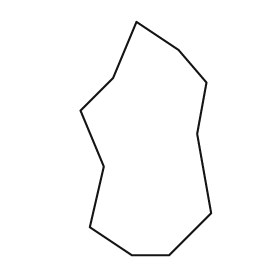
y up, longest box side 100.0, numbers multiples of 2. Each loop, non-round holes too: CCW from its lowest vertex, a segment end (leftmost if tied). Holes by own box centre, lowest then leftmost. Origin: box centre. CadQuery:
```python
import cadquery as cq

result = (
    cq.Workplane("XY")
    .moveTo(-6.0, -50.0)
    .lineTo(10.0, -50.0)
    .lineTo(28.0, -32.0)
    .lineTo(22.0, 2.0)
    .lineTo(26.0, 24.0)
    .lineTo(14.0, 38.0)
    .lineTo(-4.0, 50.0)
    .lineTo(-14.0, 26.0)
    .lineTo(-28.0, 12.0)
    .lineTo(-18.0, -12.0)
    .lineTo(-24.0, -38.0)
    .close()
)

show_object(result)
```